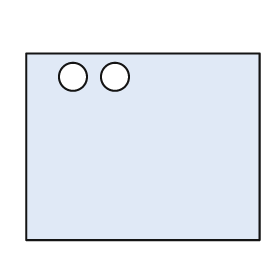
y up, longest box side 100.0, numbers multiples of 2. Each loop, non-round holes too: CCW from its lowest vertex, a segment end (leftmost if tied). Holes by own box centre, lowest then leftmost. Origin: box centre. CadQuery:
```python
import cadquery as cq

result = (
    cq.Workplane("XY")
    .moveTo(-50.0, -40.0)
    .lineTo(50.0, -40.0)
    .lineTo(50.0, 40.0)
    .lineTo(-50.0, 40.0)
    .close()
    .moveTo(-30.0, 30.0)
    .circle(6.0)
    .moveTo(-12.0, 30.0)
    .circle(6.0)
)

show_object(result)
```